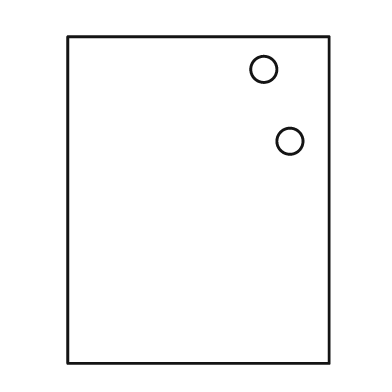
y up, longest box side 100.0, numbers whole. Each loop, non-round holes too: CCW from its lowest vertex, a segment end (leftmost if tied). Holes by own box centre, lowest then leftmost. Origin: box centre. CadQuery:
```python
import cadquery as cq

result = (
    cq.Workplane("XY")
    .moveTo(-40.0, -50.0)
    .lineTo(40.0, -50.0)
    .lineTo(40.0, 50.0)
    .lineTo(-40.0, 50.0)
    .close()
    .moveTo(28.0, 18.0)
    .circle(4.0)
    .moveTo(20.0, 40.0)
    .circle(4.0)
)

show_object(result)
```